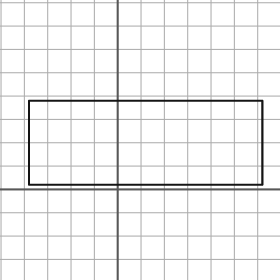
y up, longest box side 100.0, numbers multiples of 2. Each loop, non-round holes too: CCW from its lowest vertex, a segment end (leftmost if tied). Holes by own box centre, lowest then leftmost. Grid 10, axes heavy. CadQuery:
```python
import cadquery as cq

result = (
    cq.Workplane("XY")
    .moveTo(-38.0, 2.0)
    .lineTo(62.0, 2.0)
    .lineTo(62.0, 38.0)
    .lineTo(-38.0, 38.0)
    .close()
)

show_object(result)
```